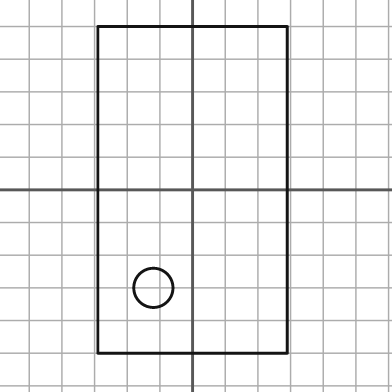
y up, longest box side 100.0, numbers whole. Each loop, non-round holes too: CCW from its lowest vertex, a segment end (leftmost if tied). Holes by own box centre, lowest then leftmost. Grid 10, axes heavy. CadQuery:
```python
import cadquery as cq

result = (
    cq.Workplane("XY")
    .moveTo(-29.0, -50.0)
    .lineTo(29.0, -50.0)
    .lineTo(29.0, 50.0)
    .lineTo(-29.0, 50.0)
    .close()
    .moveTo(-12.0, -30.0)
    .circle(6.0)
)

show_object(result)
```